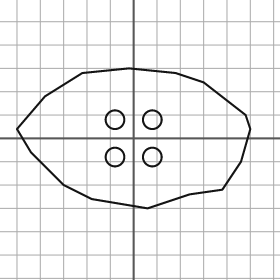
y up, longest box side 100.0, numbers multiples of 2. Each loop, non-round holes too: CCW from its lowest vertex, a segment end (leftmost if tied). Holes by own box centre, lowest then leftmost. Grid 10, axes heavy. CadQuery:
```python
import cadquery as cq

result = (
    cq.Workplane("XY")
    .moveTo(6.0, -30.0)
    .lineTo(24.0, -24.0)
    .lineTo(38.0, -22.0)
    .lineTo(46.0, -10.0)
    .lineTo(50.0, 4.0)
    .lineTo(48.0, 10.0)
    .lineTo(30.0, 24.0)
    .lineTo(18.0, 28.0)
    .lineTo(-2.0, 30.0)
    .lineTo(-22.0, 28.0)
    .lineTo(-38.0, 18.0)
    .lineTo(-50.0, 4.0)
    .lineTo(-44.0, -6.0)
    .lineTo(-30.0, -20.0)
    .lineTo(-18.0, -26.0)
    .close()
    .moveTo(-8.0, -8.0)
    .circle(4.0)
    .moveTo(8.0, -8.0)
    .circle(4.0)
    .moveTo(-8.0, 8.0)
    .circle(4.0)
    .moveTo(8.0, 8.0)
    .circle(4.0)
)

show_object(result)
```